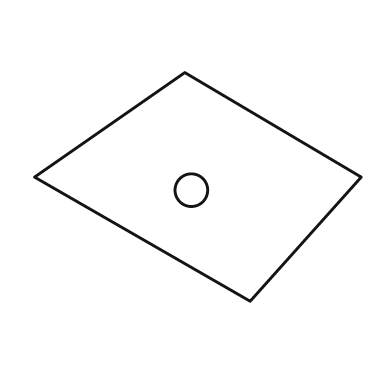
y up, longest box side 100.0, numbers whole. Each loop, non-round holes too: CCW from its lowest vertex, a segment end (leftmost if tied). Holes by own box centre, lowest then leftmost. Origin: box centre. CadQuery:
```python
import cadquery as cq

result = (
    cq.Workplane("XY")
    .moveTo(16.0, -35.0)
    .lineTo(50.0, 3.0)
    .lineTo(-4.0, 35.0)
    .lineTo(-50.0, 3.0)
    .close()
    .moveTo(-2.0, -1.0)
    .circle(5.0)
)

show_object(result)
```